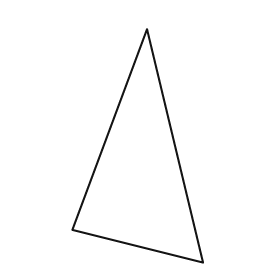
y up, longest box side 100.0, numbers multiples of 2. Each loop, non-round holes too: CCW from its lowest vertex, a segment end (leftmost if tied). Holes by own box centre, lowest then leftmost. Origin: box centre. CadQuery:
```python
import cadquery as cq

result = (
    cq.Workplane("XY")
    .moveTo(28.0, -50.0)
    .lineTo(4.0, 50.0)
    .lineTo(-28.0, -36.0)
    .close()
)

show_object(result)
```